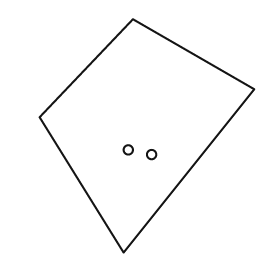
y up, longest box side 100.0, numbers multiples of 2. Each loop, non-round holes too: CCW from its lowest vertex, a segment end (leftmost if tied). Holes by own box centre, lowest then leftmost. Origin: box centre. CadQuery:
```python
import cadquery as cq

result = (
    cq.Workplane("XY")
    .moveTo(-10.0, -50.0)
    .lineTo(46.0, 20.0)
    .lineTo(-6.0, 50.0)
    .lineTo(-46.0, 8.0)
    .close()
    .moveTo(2.0, -8.0)
    .circle(2.0)
    .moveTo(-8.0, -6.0)
    .circle(2.0)
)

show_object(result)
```